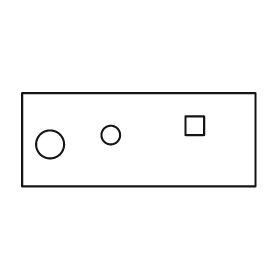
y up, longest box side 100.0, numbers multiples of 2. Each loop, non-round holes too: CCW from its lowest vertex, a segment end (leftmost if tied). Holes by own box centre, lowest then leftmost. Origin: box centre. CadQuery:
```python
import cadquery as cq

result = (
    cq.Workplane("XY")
    .moveTo(-50.0, -20.0)
    .lineTo(50.0, -20.0)
    .lineTo(50.0, 20.0)
    .lineTo(-50.0, 20.0)
    .close()
    .moveTo(-38.0, -2.0)
    .circle(6.0)
    .moveTo(-12.0, 2.0)
    .circle(4.0)
    .moveTo(20.0, 2.0)
    .lineTo(28.0, 2.0)
    .lineTo(28.0, 10.0)
    .lineTo(20.0, 10.0)
    .close()
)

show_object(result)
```